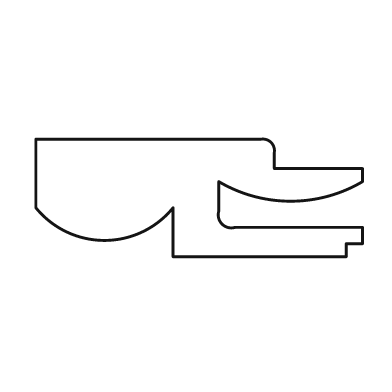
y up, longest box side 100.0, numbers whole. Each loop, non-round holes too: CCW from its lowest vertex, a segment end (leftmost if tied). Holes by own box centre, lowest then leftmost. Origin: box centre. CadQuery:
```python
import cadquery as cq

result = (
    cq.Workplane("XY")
    .moveTo(-8.0, -18.0)
    .lineTo(45.0, -18.0)
    .lineTo(45.0, -14.0)
    .lineTo(50.0, -14.0)
    .lineTo(50.0, -9.0)
    .lineTo(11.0, -9.0)
    .threePointArc((7.0, -8.0), (6.0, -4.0))
    .lineTo(6.0, 5.0)
    .threePointArc((28.0, -1.0), (50.0, 5.0))
    .lineTo(50.0, 9.0)
    .lineTo(23.0, 9.0)
    .lineTo(23.0, 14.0)
    .threePointArc((22.0, 17.0), (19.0, 18.0))
    .lineTo(-50.0, 18.0)
    .lineTo(-50.0, -3.0)
    .threePointArc((-29.0, -13.0), (-8.0, -3.0))
    .close()
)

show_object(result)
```